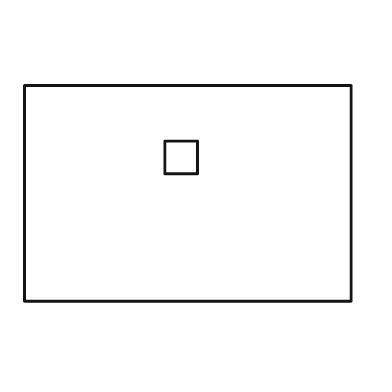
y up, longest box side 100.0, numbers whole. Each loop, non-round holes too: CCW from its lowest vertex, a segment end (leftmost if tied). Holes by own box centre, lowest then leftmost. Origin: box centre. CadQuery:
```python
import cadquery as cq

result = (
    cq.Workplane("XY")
    .moveTo(-50.0, -33.0)
    .lineTo(50.0, -33.0)
    .lineTo(50.0, 33.0)
    .lineTo(-50.0, 33.0)
    .close()
    .moveTo(-7.0, 6.0)
    .lineTo(3.0, 6.0)
    .lineTo(3.0, 16.0)
    .lineTo(-7.0, 16.0)
    .close()
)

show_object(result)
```